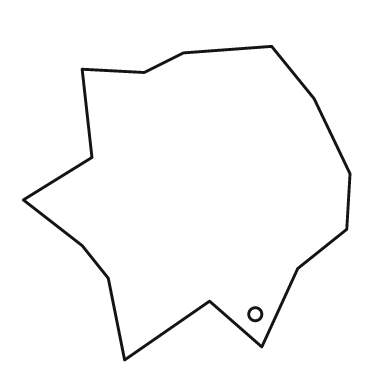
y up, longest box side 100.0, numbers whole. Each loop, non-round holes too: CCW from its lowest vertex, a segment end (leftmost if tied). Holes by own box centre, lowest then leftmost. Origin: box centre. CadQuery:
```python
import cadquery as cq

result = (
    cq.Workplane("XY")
    .moveTo(-19.0, -48.0)
    .lineTo(7.0, -30.0)
    .lineTo(23.0, -44.0)
    .lineTo(34.0, -20.0)
    .lineTo(49.0, -8.0)
    .lineTo(50.0, 9.0)
    .lineTo(39.0, 32.0)
    .lineTo(26.0, 48.0)
    .lineTo(-1.0, 46.0)
    .lineTo(-13.0, 40.0)
    .lineTo(-32.0, 41.0)
    .lineTo(-29.0, 14.0)
    .lineTo(-50.0, 1.0)
    .lineTo(-32.0, -13.0)
    .lineTo(-24.0, -23.0)
    .close()
    .moveTo(21.0, -34.0)
    .circle(2.0)
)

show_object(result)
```